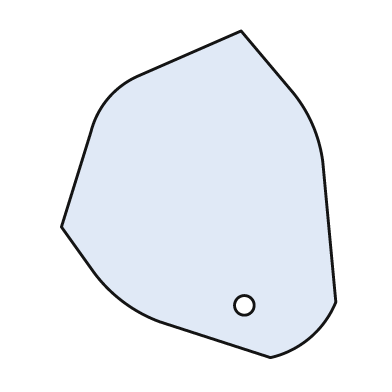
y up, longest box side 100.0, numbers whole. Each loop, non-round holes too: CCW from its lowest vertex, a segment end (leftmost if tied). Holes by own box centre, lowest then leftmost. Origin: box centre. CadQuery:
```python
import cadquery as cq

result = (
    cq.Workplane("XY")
    .moveTo(22.0, -50.0)
    .threePointArc((34.0, -44.0), (42.0, -33.0))
    .lineTo(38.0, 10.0)
    .threePointArc((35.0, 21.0), (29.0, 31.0))
    .lineTo(13.0, 50.0)
    .lineTo(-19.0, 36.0)
    .threePointArc((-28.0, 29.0), (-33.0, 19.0))
    .lineTo(-42.0, -10.0)
    .lineTo(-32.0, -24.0)
    .threePointArc((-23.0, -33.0), (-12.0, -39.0))
    .close()
    .moveTo(14.0, -34.0)
    .circle(3.0)
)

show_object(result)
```